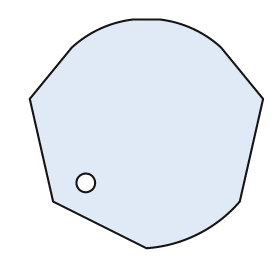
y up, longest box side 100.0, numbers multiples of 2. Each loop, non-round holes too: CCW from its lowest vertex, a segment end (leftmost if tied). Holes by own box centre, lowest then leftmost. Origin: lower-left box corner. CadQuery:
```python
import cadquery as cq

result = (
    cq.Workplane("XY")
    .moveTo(50.0, 0.0)
    .threePointArc((72.0, 6.0), (90.0, 20.0))
    .lineTo(100.0, 64.0)
    .lineTo(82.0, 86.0)
    .threePointArc((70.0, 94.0), (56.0, 98.0))
    .lineTo(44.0, 98.0)
    .threePointArc((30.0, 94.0), (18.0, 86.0))
    .lineTo(0.0, 64.0)
    .lineTo(10.0, 20.0)
    .close()
    .moveTo(24.0, 28.0)
    .circle(4.0)
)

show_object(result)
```